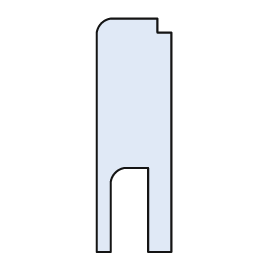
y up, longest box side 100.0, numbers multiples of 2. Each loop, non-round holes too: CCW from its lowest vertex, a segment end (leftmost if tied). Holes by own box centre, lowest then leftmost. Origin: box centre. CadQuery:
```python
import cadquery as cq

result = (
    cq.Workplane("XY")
    .moveTo(-16.0, -50.0)
    .lineTo(-10.0, -50.0)
    .lineTo(-10.0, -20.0)
    .threePointArc((-8.0, -16.0), (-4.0, -14.0))
    .lineTo(6.0, -14.0)
    .lineTo(6.0, -50.0)
    .lineTo(16.0, -50.0)
    .lineTo(16.0, 44.0)
    .lineTo(10.0, 44.0)
    .lineTo(10.0, 50.0)
    .lineTo(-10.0, 50.0)
    .threePointArc((-14.0, 48.0), (-16.0, 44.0))
    .close()
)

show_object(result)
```